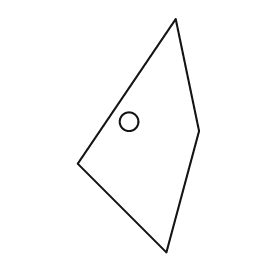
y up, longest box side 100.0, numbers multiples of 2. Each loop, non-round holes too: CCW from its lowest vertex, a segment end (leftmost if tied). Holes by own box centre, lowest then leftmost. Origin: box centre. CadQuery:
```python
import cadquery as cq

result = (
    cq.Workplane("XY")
    .moveTo(12.0, -50.0)
    .lineTo(26.0, 2.0)
    .lineTo(16.0, 50.0)
    .lineTo(-26.0, -12.0)
    .close()
    .moveTo(-4.0, 6.0)
    .circle(4.0)
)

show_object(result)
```